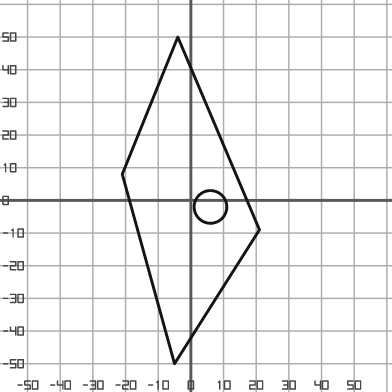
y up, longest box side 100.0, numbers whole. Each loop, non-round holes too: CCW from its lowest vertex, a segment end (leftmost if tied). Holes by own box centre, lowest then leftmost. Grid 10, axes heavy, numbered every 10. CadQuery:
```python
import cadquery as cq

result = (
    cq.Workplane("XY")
    .moveTo(-5.0, -50.0)
    .lineTo(21.0, -9.0)
    .lineTo(-4.0, 50.0)
    .lineTo(-21.0, 8.0)
    .close()
    .moveTo(6.0, -2.0)
    .circle(5.0)
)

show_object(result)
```